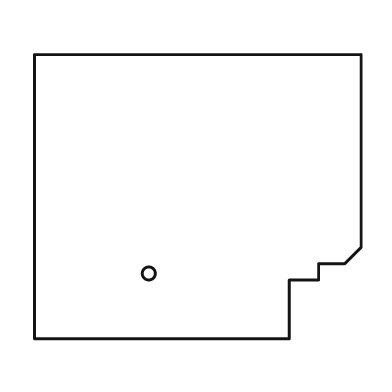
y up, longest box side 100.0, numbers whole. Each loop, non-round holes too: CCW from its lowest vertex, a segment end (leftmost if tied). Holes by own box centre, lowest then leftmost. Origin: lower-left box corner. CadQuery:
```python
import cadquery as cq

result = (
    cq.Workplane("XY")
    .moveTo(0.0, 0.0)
    .lineTo(78.0, 0.0)
    .lineTo(78.0, 18.0)
    .lineTo(87.0, 18.0)
    .lineTo(87.0, 23.0)
    .lineTo(95.0, 23.0)
    .lineTo(100.0, 28.0)
    .lineTo(100.0, 87.0)
    .lineTo(0.0, 87.0)
    .close()
    .moveTo(35.0, 20.0)
    .circle(2.0)
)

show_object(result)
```